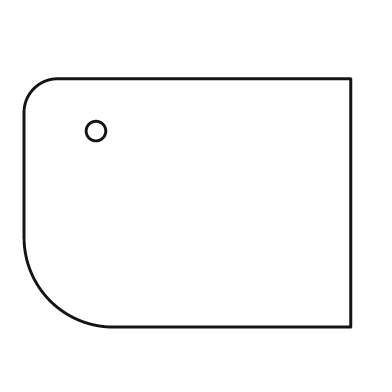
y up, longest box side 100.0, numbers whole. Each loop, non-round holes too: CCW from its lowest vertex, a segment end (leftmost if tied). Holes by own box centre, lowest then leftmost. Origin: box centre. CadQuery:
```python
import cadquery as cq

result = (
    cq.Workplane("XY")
    .moveTo(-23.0, -38.0)
    .lineTo(50.0, -38.0)
    .lineTo(50.0, 38.0)
    .lineTo(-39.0, 38.0)
    .threePointArc((-47.0, 35.0), (-50.0, 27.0))
    .lineTo(-50.0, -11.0)
    .threePointArc((-42.0, -30.0), (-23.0, -38.0))
    .close()
    .moveTo(-28.0, 22.0)
    .circle(3.0)
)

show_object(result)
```